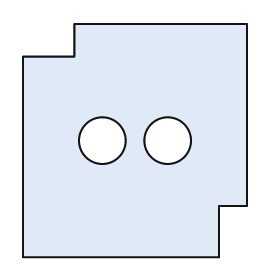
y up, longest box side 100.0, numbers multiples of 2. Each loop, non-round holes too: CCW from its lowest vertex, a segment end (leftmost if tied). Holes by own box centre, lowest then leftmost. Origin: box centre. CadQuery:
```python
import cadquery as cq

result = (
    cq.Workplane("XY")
    .moveTo(-48.0, -50.0)
    .lineTo(36.0, -50.0)
    .lineTo(36.0, -28.0)
    .lineTo(48.0, -28.0)
    .lineTo(48.0, 50.0)
    .lineTo(-26.0, 50.0)
    .lineTo(-26.0, 36.0)
    .lineTo(-48.0, 36.0)
    .close()
    .moveTo(-14.0, 0.0)
    .circle(10.0)
    .moveTo(14.0, 0.0)
    .circle(10.0)
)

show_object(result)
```